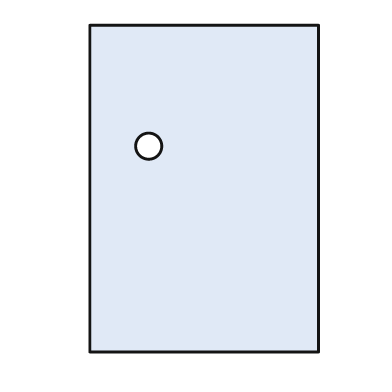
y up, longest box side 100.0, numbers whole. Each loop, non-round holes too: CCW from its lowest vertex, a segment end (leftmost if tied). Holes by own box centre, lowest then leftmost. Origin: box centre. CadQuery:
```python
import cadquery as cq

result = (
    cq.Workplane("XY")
    .moveTo(-35.0, -50.0)
    .lineTo(35.0, -50.0)
    .lineTo(35.0, 50.0)
    .lineTo(-35.0, 50.0)
    .close()
    .moveTo(-17.0, 13.0)
    .circle(4.0)
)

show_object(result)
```